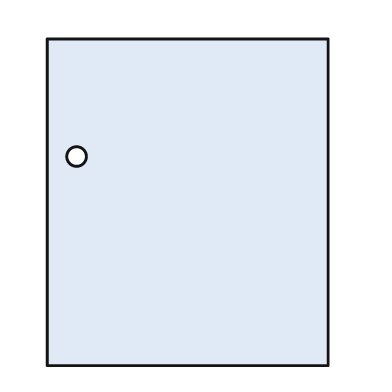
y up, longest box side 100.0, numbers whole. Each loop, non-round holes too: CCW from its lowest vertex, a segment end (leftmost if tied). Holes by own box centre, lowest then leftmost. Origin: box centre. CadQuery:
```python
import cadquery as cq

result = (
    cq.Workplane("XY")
    .moveTo(-43.0, -50.0)
    .lineTo(43.0, -50.0)
    .lineTo(43.0, 50.0)
    .lineTo(-43.0, 50.0)
    .close()
    .moveTo(-34.0, 14.0)
    .circle(3.0)
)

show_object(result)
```